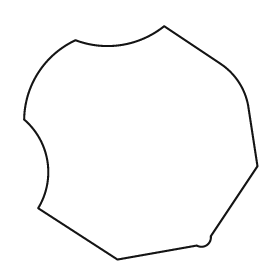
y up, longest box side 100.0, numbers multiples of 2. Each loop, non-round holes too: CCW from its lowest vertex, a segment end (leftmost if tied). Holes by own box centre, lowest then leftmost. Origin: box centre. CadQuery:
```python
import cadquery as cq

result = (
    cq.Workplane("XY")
    .moveTo(-10.0, -50.0)
    .lineTo(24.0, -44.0)
    .threePointArc((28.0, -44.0), (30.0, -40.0))
    .lineTo(50.0, -10.0)
    .lineTo(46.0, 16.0)
    .threePointArc((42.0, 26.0), (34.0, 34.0))
    .lineTo(10.0, 50.0)
    .threePointArc((-8.0, 42.0), (-28.0, 44.0))
    .threePointArc((-44.0, 30.0), (-50.0, 10.0))
    .threePointArc((-40.0, -8.0), (-44.0, -28.0))
    .close()
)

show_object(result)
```